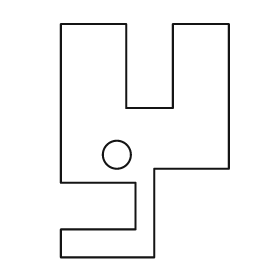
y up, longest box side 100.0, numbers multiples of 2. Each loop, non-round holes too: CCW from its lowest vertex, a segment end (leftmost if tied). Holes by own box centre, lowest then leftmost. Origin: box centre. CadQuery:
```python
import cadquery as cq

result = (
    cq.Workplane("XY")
    .moveTo(-36.0, -50.0)
    .lineTo(4.0, -50.0)
    .lineTo(4.0, -12.0)
    .lineTo(36.0, -12.0)
    .lineTo(36.0, 50.0)
    .lineTo(12.0, 50.0)
    .lineTo(12.0, 14.0)
    .lineTo(-8.0, 14.0)
    .lineTo(-8.0, 50.0)
    .lineTo(-36.0, 50.0)
    .lineTo(-36.0, -18.0)
    .lineTo(-4.0, -18.0)
    .lineTo(-4.0, -38.0)
    .lineTo(-36.0, -38.0)
    .close()
    .moveTo(-12.0, -6.0)
    .circle(6.0)
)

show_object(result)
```